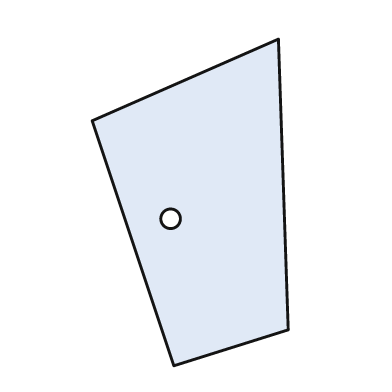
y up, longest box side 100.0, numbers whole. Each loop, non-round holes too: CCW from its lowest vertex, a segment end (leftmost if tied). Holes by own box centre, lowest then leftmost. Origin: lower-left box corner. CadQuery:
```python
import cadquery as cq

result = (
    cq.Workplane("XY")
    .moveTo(25.0, 0.0)
    .lineTo(60.0, 11.0)
    .lineTo(57.0, 100.0)
    .lineTo(0.0, 75.0)
    .close()
    .moveTo(24.0, 45.0)
    .circle(3.0)
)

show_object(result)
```